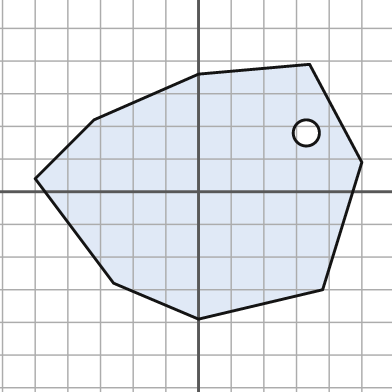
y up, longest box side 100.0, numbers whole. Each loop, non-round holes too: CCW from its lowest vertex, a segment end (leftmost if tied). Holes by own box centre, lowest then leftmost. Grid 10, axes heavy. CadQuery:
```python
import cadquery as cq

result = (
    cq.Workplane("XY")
    .moveTo(0.0, -39.0)
    .lineTo(38.0, -30.0)
    .lineTo(50.0, 9.0)
    .lineTo(34.0, 39.0)
    .lineTo(0.0, 36.0)
    .lineTo(-32.0, 22.0)
    .lineTo(-50.0, 4.0)
    .lineTo(-26.0, -28.0)
    .close()
    .moveTo(33.0, 18.0)
    .circle(4.0)
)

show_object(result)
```